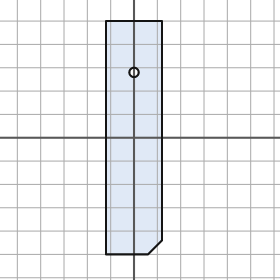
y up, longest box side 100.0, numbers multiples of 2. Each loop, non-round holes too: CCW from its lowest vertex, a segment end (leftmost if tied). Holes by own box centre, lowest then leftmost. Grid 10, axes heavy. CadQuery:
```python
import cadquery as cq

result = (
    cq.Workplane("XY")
    .moveTo(-12.0, -50.0)
    .lineTo(6.0, -50.0)
    .lineTo(12.0, -44.0)
    .lineTo(12.0, 50.0)
    .lineTo(-12.0, 50.0)
    .close()
    .moveTo(0.0, 28.0)
    .circle(2.0)
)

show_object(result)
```